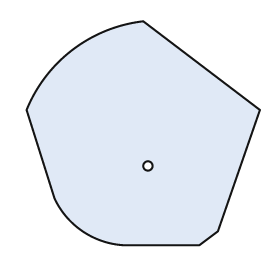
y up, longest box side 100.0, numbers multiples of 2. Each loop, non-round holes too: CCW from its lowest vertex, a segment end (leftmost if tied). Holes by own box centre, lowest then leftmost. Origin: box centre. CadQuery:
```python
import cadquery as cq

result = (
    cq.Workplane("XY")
    .moveTo(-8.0, -48.0)
    .lineTo(24.0, -48.0)
    .lineTo(32.0, -42.0)
    .lineTo(50.0, 10.0)
    .lineTo(0.0, 48.0)
    .threePointArc((-30.0, 36.0), (-50.0, 10.0))
    .lineTo(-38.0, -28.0)
    .threePointArc((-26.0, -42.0), (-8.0, -48.0))
    .close()
    .moveTo(2.0, -14.0)
    .circle(2.0)
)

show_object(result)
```